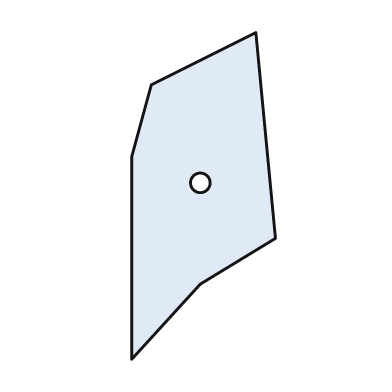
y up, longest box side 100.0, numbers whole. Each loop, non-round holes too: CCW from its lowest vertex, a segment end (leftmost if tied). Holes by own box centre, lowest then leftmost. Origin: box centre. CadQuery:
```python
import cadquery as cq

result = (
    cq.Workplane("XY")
    .moveTo(-22.0, -50.0)
    .lineTo(-1.0, -27.0)
    .lineTo(22.0, -13.0)
    .lineTo(16.0, 50.0)
    .lineTo(-16.0, 34.0)
    .lineTo(-22.0, 12.0)
    .close()
    .moveTo(-1.0, 4.0)
    .circle(3.0)
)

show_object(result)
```